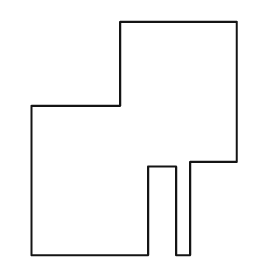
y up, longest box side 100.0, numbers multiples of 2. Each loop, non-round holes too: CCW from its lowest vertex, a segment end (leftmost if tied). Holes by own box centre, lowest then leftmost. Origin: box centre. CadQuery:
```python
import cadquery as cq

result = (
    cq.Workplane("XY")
    .moveTo(-44.0, -50.0)
    .lineTo(6.0, -50.0)
    .lineTo(6.0, -12.0)
    .lineTo(18.0, -12.0)
    .lineTo(18.0, -50.0)
    .lineTo(24.0, -50.0)
    .lineTo(24.0, -10.0)
    .lineTo(44.0, -10.0)
    .lineTo(44.0, 50.0)
    .lineTo(-6.0, 50.0)
    .lineTo(-6.0, 14.0)
    .lineTo(-44.0, 14.0)
    .close()
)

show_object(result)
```